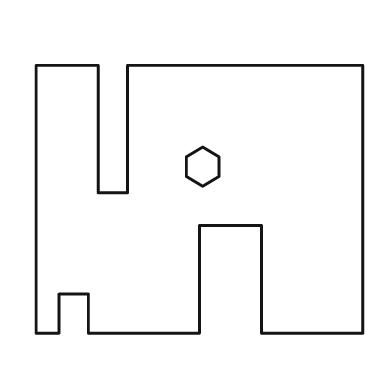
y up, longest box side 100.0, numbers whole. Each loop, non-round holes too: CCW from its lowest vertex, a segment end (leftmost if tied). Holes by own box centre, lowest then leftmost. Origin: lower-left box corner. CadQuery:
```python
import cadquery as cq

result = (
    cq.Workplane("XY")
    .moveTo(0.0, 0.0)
    .lineTo(7.0, 0.0)
    .lineTo(7.0, 12.0)
    .lineTo(16.0, 12.0)
    .lineTo(16.0, 0.0)
    .lineTo(50.0, 0.0)
    .lineTo(50.0, 33.0)
    .lineTo(69.0, 33.0)
    .lineTo(69.0, 0.0)
    .lineTo(100.0, 0.0)
    .lineTo(100.0, 82.0)
    .lineTo(28.0, 82.0)
    .lineTo(28.0, 43.0)
    .lineTo(19.0, 43.0)
    .lineTo(19.0, 82.0)
    .lineTo(0.0, 82.0)
    .close()
    .moveTo(51.0, 45.0)
    .lineTo(56.0, 48.0)
    .lineTo(56.0, 54.0)
    .lineTo(51.0, 57.0)
    .lineTo(46.0, 54.0)
    .lineTo(46.0, 48.0)
    .close()
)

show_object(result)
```